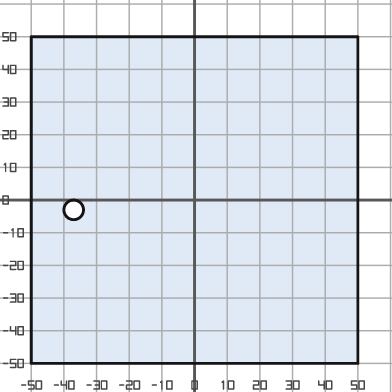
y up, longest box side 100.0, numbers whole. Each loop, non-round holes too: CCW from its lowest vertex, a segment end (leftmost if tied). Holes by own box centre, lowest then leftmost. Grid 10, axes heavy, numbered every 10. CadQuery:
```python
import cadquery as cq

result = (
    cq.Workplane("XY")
    .moveTo(-50.0, -50.0)
    .lineTo(50.0, -50.0)
    .lineTo(50.0, 50.0)
    .lineTo(-50.0, 50.0)
    .close()
    .moveTo(-37.0, -3.0)
    .circle(3.0)
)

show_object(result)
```